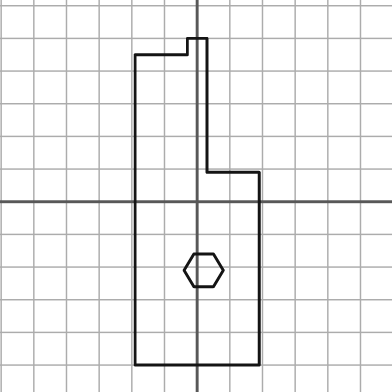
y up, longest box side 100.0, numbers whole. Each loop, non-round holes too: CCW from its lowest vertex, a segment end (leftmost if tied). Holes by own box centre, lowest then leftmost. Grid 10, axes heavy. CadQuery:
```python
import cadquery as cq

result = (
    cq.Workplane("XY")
    .moveTo(-19.0, -50.0)
    .lineTo(19.0, -50.0)
    .lineTo(19.0, 9.0)
    .lineTo(3.0, 9.0)
    .lineTo(3.0, 50.0)
    .lineTo(-3.0, 50.0)
    .lineTo(-3.0, 45.0)
    .lineTo(-19.0, 45.0)
    .close()
    .moveTo(-1.0, -26.0)
    .lineTo(5.0, -26.0)
    .lineTo(8.0, -21.0)
    .lineTo(5.0, -16.0)
    .lineTo(-1.0, -16.0)
    .lineTo(-4.0, -21.0)
    .close()
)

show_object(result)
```